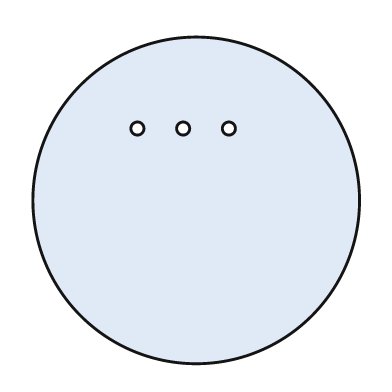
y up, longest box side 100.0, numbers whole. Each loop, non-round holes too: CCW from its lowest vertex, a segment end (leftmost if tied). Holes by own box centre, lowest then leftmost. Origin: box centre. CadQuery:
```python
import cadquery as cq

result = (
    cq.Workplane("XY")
    .moveTo(0.0, 0.0)
    .circle(50.0)
    .moveTo(-18.0, 22.0)
    .circle(2.0)
    .moveTo(-4.0, 22.0)
    .circle(2.0)
    .moveTo(10.0, 22.0)
    .circle(2.0)
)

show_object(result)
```